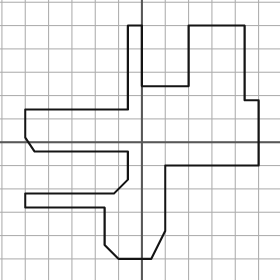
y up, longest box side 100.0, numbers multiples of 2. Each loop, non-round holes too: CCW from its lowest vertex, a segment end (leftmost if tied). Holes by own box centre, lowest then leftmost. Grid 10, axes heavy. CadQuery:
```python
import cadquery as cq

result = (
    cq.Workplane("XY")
    .moveTo(-10.0, -50.0)
    .lineTo(4.0, -50.0)
    .lineTo(10.0, -38.0)
    .lineTo(10.0, -10.0)
    .lineTo(50.0, -10.0)
    .lineTo(50.0, 18.0)
    .lineTo(44.0, 18.0)
    .lineTo(44.0, 50.0)
    .lineTo(20.0, 50.0)
    .lineTo(20.0, 24.0)
    .lineTo(0.0, 24.0)
    .lineTo(0.0, 50.0)
    .lineTo(-6.0, 50.0)
    .lineTo(-6.0, 14.0)
    .lineTo(-50.0, 14.0)
    .lineTo(-50.0, 2.0)
    .lineTo(-46.0, -4.0)
    .lineTo(-6.0, -4.0)
    .lineTo(-6.0, -16.0)
    .lineTo(-12.0, -22.0)
    .lineTo(-50.0, -22.0)
    .lineTo(-50.0, -28.0)
    .lineTo(-16.0, -28.0)
    .lineTo(-16.0, -44.0)
    .close()
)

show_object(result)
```